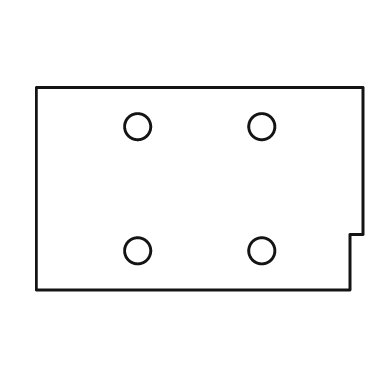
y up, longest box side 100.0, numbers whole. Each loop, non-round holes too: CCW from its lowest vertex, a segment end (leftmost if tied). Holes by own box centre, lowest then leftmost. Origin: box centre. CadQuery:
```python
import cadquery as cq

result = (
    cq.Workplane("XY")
    .moveTo(-50.0, -31.0)
    .lineTo(46.0, -31.0)
    .lineTo(46.0, -14.0)
    .lineTo(50.0, -14.0)
    .lineTo(50.0, 31.0)
    .lineTo(-50.0, 31.0)
    .close()
    .moveTo(-19.0, -19.0)
    .circle(4.0)
    .moveTo(19.0, -19.0)
    .circle(4.0)
    .moveTo(-19.0, 19.0)
    .circle(4.0)
    .moveTo(19.0, 19.0)
    .circle(4.0)
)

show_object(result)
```